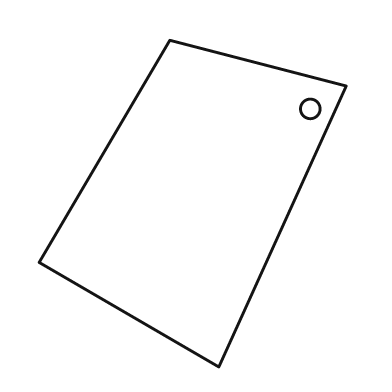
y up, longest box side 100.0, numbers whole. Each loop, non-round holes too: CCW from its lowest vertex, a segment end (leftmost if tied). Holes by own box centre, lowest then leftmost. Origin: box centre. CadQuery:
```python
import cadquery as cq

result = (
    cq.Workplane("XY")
    .moveTo(8.0, -50.0)
    .lineTo(47.0, 36.0)
    .lineTo(-7.0, 50.0)
    .lineTo(-47.0, -18.0)
    .close()
    .moveTo(36.0, 29.0)
    .circle(3.0)
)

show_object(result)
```